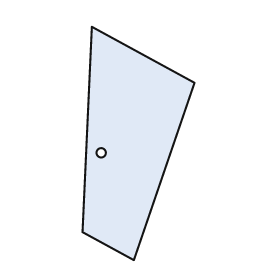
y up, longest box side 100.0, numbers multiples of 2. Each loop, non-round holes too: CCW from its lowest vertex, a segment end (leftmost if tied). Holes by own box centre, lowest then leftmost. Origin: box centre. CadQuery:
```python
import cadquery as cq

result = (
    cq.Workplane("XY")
    .moveTo(-2.0, -50.0)
    .lineTo(24.0, 26.0)
    .lineTo(-20.0, 50.0)
    .lineTo(-24.0, -38.0)
    .close()
    .moveTo(-16.0, -4.0)
    .circle(2.0)
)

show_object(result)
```